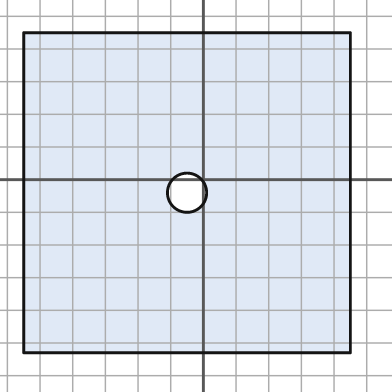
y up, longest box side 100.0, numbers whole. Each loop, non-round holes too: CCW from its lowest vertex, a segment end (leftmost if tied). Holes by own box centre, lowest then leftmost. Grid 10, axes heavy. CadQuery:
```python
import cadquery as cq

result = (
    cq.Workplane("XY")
    .moveTo(-55.0, -53.0)
    .lineTo(45.0, -53.0)
    .lineTo(45.0, 45.0)
    .lineTo(-55.0, 45.0)
    .close()
    .moveTo(-5.0, -4.0)
    .circle(6.0)
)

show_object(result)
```